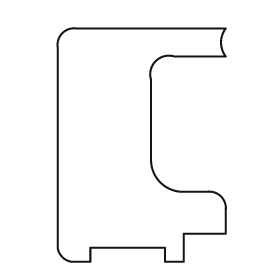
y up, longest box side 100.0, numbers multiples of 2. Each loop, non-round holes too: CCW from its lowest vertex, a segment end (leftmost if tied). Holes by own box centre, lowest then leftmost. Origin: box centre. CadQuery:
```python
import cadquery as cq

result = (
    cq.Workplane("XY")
    .moveTo(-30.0, -50.0)
    .lineTo(-22.0, -50.0)
    .lineTo(-22.0, -44.0)
    .lineTo(10.0, -44.0)
    .lineTo(10.0, -50.0)
    .lineTo(18.0, -50.0)
    .lineTo(18.0, -38.0)
    .lineTo(36.0, -38.0)
    .lineTo(36.0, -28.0)
    .threePointArc((34.0, -22.0), (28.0, -20.0))
    .lineTo(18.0, -20.0)
    .threePointArc((8.0, -16.0), (4.0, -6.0))
    .lineTo(4.0, 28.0)
    .threePointArc((6.0, 36.0), (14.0, 38.0))
    .lineTo(36.0, 38.0)
    .threePointArc((34.0, 44.0), (36.0, 50.0))
    .lineTo(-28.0, 50.0)
    .threePointArc((-34.0, 48.0), (-36.0, 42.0))
    .lineTo(-36.0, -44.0)
    .threePointArc((-34.0, -48.0), (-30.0, -50.0))
    .close()
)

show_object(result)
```